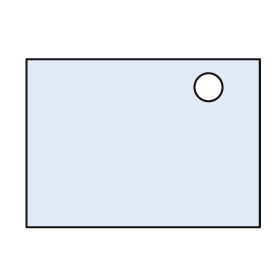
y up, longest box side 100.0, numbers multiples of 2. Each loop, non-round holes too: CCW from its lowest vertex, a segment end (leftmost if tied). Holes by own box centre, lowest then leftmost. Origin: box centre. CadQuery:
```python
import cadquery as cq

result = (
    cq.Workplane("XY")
    .moveTo(-50.0, -36.0)
    .lineTo(50.0, -36.0)
    .lineTo(50.0, 36.0)
    .lineTo(-50.0, 36.0)
    .close()
    .moveTo(28.0, 24.0)
    .circle(6.0)
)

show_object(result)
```